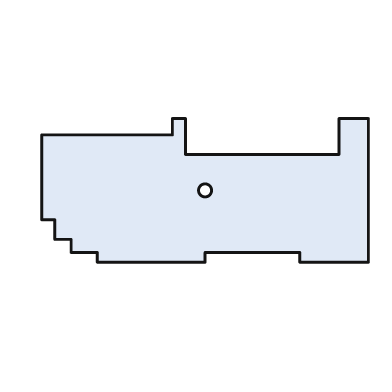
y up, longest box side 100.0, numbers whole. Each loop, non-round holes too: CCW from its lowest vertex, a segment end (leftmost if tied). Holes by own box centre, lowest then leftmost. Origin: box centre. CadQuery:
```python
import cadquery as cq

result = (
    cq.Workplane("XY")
    .moveTo(-33.0, -22.0)
    .lineTo(0.0, -22.0)
    .lineTo(0.0, -19.0)
    .lineTo(29.0, -19.0)
    .lineTo(29.0, -22.0)
    .lineTo(50.0, -22.0)
    .lineTo(50.0, 22.0)
    .lineTo(41.0, 22.0)
    .lineTo(41.0, 11.0)
    .lineTo(-6.0, 11.0)
    .lineTo(-6.0, 22.0)
    .lineTo(-10.0, 22.0)
    .lineTo(-10.0, 17.0)
    .lineTo(-50.0, 17.0)
    .lineTo(-50.0, -9.0)
    .lineTo(-46.0, -9.0)
    .lineTo(-46.0, -15.0)
    .lineTo(-41.0, -15.0)
    .lineTo(-41.0, -19.0)
    .lineTo(-33.0, -19.0)
    .close()
    .moveTo(0.0, 0.0)
    .circle(2.0)
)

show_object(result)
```